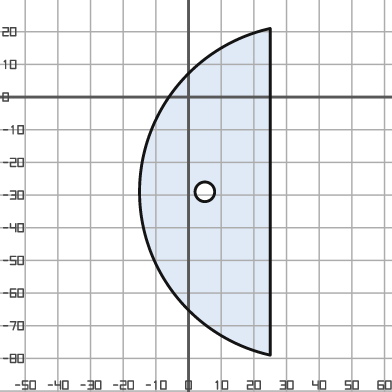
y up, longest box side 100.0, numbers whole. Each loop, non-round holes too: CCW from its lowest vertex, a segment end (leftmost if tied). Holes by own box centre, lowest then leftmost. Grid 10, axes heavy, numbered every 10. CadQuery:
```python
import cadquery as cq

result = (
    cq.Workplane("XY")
    .moveTo(25.0, -79.0)
    .lineTo(25.0, 21.0)
    .threePointArc((-15.0, -29.0), (25.0, -79.0))
    .close()
    .moveTo(5.0, -29.0)
    .circle(3.0)
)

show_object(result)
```